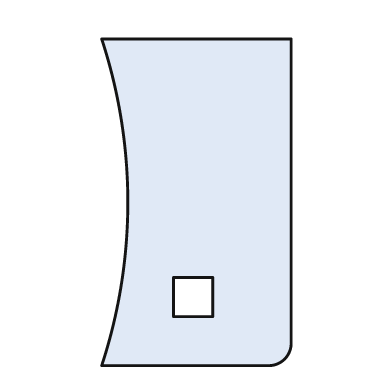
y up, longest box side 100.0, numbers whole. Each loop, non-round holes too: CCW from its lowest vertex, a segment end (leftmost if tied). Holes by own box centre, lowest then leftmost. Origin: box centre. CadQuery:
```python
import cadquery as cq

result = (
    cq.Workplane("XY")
    .moveTo(-29.0, -50.0)
    .lineTo(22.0, -50.0)
    .threePointArc((27.0, -48.0), (29.0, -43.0))
    .lineTo(29.0, 50.0)
    .lineTo(-29.0, 50.0)
    .threePointArc((-21.0, 0.0), (-29.0, -50.0))
    .close()
    .moveTo(-7.0, -35.0)
    .lineTo(5.0, -35.0)
    .lineTo(5.0, -23.0)
    .lineTo(-7.0, -23.0)
    .close()
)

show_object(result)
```